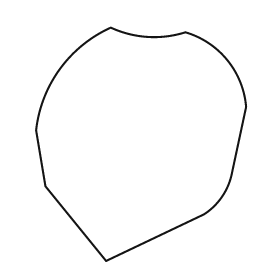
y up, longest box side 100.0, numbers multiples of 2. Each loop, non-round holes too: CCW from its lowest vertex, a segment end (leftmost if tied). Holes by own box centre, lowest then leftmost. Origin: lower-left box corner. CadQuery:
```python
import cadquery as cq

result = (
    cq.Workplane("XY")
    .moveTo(30.0, 0.0)
    .lineTo(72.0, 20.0)
    .threePointArc((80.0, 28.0), (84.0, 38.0))
    .lineTo(90.0, 66.0)
    .threePointArc((82.0, 86.0), (64.0, 98.0))
    .threePointArc((48.0, 96.0), (32.0, 100.0))
    .threePointArc((10.0, 82.0), (0.0, 56.0))
    .lineTo(4.0, 32.0)
    .close()
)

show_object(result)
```